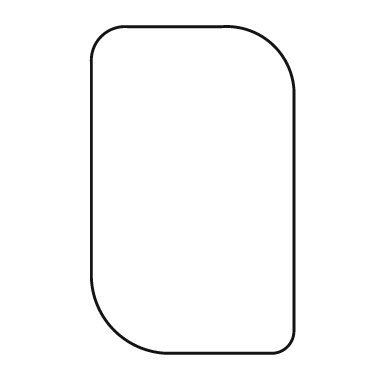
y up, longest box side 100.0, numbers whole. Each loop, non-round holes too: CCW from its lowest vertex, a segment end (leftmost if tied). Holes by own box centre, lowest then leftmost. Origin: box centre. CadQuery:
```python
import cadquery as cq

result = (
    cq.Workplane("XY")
    .moveTo(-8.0, -50.0)
    .lineTo(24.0, -50.0)
    .threePointArc((29.0, -48.0), (31.0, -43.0))
    .lineTo(31.0, 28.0)
    .threePointArc((25.0, 44.0), (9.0, 50.0))
    .lineTo(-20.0, 50.0)
    .threePointArc((-28.0, 47.0), (-31.0, 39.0))
    .lineTo(-31.0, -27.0)
    .threePointArc((-24.0, -43.0), (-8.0, -50.0))
    .close()
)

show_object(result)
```